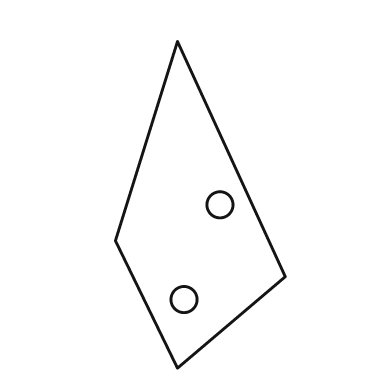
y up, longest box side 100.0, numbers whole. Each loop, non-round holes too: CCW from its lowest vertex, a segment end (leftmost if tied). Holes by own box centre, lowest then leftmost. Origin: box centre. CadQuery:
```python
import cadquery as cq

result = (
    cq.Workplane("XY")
    .moveTo(-7.0, -50.0)
    .lineTo(26.0, -22.0)
    .lineTo(-7.0, 50.0)
    .lineTo(-26.0, -11.0)
    .close()
    .moveTo(-5.0, -29.0)
    .circle(4.0)
    .moveTo(6.0, 0.0)
    .circle(4.0)
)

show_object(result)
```